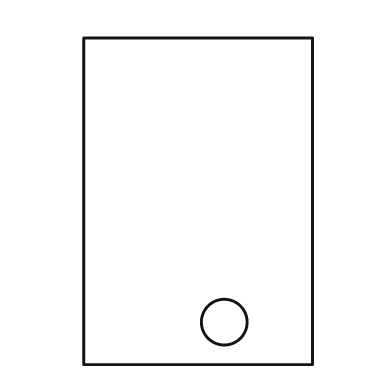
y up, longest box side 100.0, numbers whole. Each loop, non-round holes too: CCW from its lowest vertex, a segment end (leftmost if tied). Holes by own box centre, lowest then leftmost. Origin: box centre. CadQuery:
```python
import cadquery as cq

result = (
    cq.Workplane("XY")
    .moveTo(-35.0, -50.0)
    .lineTo(35.0, -50.0)
    .lineTo(35.0, 50.0)
    .lineTo(-35.0, 50.0)
    .close()
    .moveTo(8.0, -37.0)
    .circle(7.0)
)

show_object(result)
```